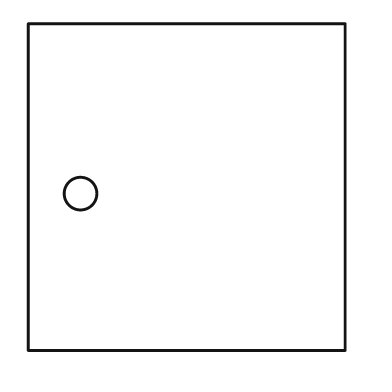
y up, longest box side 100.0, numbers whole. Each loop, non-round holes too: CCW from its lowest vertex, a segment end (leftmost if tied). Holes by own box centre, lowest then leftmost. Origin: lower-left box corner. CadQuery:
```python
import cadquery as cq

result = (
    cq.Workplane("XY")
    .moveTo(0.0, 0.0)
    .lineTo(97.0, 0.0)
    .lineTo(97.0, 100.0)
    .lineTo(0.0, 100.0)
    .close()
    .moveTo(16.0, 48.0)
    .circle(5.0)
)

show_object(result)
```